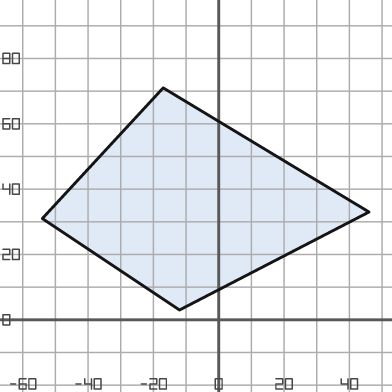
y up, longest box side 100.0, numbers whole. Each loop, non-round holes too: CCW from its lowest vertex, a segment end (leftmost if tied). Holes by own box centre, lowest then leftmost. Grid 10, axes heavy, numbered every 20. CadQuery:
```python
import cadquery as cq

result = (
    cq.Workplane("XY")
    .moveTo(-12.0, 3.0)
    .lineTo(46.0, 33.0)
    .lineTo(-17.0, 71.0)
    .lineTo(-54.0, 31.0)
    .close()
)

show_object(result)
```